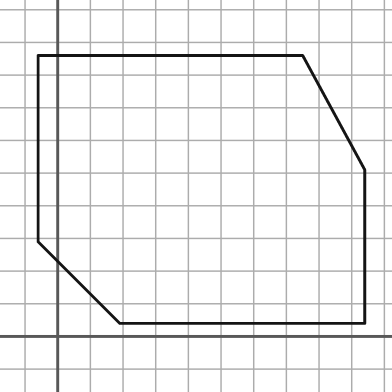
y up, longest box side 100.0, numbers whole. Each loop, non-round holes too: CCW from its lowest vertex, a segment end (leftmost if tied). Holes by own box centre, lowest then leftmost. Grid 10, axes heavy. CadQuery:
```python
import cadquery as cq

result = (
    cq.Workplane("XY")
    .moveTo(19.0, 4.0)
    .lineTo(94.0, 4.0)
    .lineTo(94.0, 51.0)
    .lineTo(75.0, 86.0)
    .lineTo(-6.0, 86.0)
    .lineTo(-6.0, 29.0)
    .close()
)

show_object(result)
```